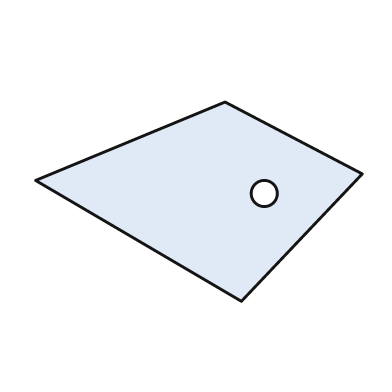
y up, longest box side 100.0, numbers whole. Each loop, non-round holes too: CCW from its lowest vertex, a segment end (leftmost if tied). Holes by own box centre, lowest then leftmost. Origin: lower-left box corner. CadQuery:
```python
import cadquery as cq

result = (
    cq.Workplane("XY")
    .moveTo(63.0, 0.0)
    .lineTo(100.0, 39.0)
    .lineTo(58.0, 61.0)
    .lineTo(0.0, 37.0)
    .close()
    .moveTo(70.0, 33.0)
    .circle(4.0)
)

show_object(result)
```